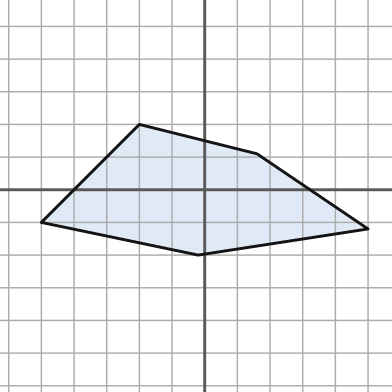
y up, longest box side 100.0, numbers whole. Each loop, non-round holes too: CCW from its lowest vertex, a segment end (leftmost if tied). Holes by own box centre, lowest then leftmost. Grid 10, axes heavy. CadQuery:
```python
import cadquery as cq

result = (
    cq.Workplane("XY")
    .moveTo(-2.0, -20.0)
    .lineTo(50.0, -12.0)
    .lineTo(16.0, 11.0)
    .lineTo(-20.0, 20.0)
    .lineTo(-50.0, -10.0)
    .close()
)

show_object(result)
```